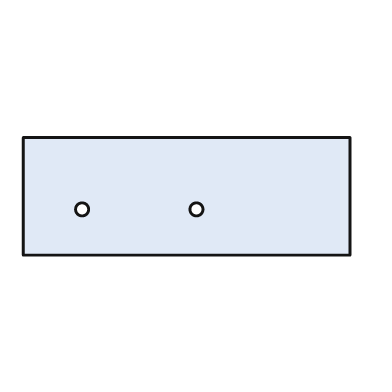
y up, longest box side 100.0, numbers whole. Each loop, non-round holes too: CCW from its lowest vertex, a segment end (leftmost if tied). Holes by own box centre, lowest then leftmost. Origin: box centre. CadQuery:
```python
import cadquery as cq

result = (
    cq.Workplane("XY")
    .moveTo(-50.0, -18.0)
    .lineTo(50.0, -18.0)
    .lineTo(50.0, 18.0)
    .lineTo(-50.0, 18.0)
    .close()
    .moveTo(-32.0, -4.0)
    .circle(2.0)
    .moveTo(3.0, -4.0)
    .circle(2.0)
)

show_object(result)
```